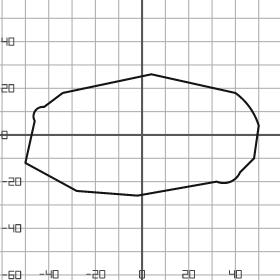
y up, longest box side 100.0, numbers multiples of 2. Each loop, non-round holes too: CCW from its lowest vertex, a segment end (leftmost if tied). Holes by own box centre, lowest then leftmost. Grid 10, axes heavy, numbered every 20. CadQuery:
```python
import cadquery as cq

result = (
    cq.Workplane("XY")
    .moveTo(-2.0, -26.0)
    .lineTo(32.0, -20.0)
    .threePointArc((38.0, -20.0), (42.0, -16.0))
    .lineTo(48.0, -10.0)
    .lineTo(50.0, 4.0)
    .threePointArc((46.0, 12.0), (40.0, 18.0))
    .lineTo(4.0, 26.0)
    .lineTo(-34.0, 18.0)
    .lineTo(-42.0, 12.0)
    .threePointArc((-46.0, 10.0), (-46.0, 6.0))
    .lineTo(-50.0, -12.0)
    .lineTo(-28.0, -24.0)
    .close()
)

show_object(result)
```